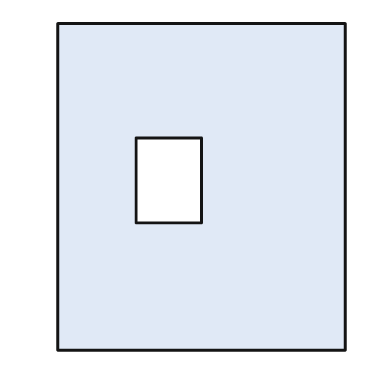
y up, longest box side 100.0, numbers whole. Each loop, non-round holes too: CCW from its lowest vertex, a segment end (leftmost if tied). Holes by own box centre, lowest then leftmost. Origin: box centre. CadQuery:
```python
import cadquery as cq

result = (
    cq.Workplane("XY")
    .moveTo(-44.0, -50.0)
    .lineTo(44.0, -50.0)
    .lineTo(44.0, 50.0)
    .lineTo(-44.0, 50.0)
    .close()
    .moveTo(-20.0, -11.0)
    .lineTo(0.0, -11.0)
    .lineTo(0.0, 15.0)
    .lineTo(-20.0, 15.0)
    .close()
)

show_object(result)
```